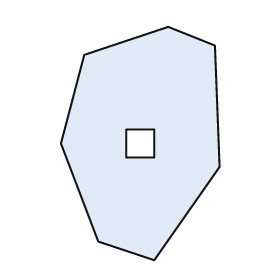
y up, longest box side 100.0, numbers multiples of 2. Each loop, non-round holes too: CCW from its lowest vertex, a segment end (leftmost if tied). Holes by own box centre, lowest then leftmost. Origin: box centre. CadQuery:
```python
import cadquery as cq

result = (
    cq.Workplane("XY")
    .moveTo(6.0, -50.0)
    .lineTo(34.0, -10.0)
    .lineTo(32.0, 42.0)
    .lineTo(12.0, 50.0)
    .lineTo(-24.0, 38.0)
    .lineTo(-34.0, 0.0)
    .lineTo(-18.0, -42.0)
    .close()
    .moveTo(-6.0, -6.0)
    .lineTo(6.0, -6.0)
    .lineTo(6.0, 6.0)
    .lineTo(-6.0, 6.0)
    .close()
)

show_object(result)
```